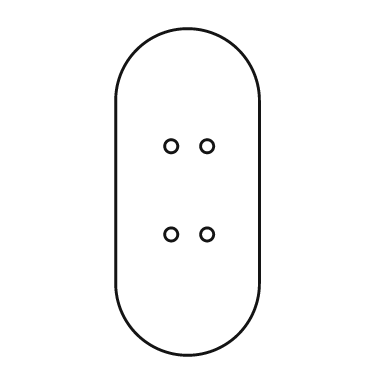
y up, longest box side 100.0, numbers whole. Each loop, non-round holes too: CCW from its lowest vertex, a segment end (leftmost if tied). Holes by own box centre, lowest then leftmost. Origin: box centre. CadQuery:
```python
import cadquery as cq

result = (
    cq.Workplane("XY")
    .moveTo(-22.0, -28.0)
    .threePointArc((0.0, -50.0), (22.0, -28.0))
    .lineTo(22.0, 28.0)
    .threePointArc((0.0, 50.0), (-22.0, 28.0))
    .close()
    .moveTo(-5.0, -13.0)
    .circle(2.0)
    .moveTo(6.0, -13.0)
    .circle(2.0)
    .moveTo(-5.0, 14.0)
    .circle(2.0)
    .moveTo(6.0, 14.0)
    .circle(2.0)
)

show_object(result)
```